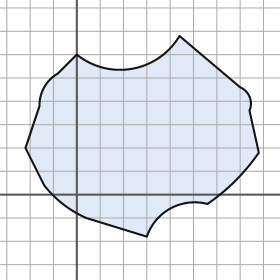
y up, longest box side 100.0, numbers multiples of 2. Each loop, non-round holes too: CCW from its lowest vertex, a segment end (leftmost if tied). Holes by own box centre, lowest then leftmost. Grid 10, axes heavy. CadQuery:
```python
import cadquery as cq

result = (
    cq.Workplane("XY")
    .moveTo(30.0, -18.0)
    .threePointArc((40.0, -6.0), (56.0, -4.0))
    .threePointArc((68.0, 6.0), (78.0, 18.0))
    .lineTo(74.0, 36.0)
    .threePointArc((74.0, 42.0), (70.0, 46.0))
    .lineTo(44.0, 68.0)
    .threePointArc((24.0, 54.0), (0.0, 60.0))
    .lineTo(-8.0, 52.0)
    .threePointArc((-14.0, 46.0), (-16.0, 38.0))
    .lineTo(-22.0, 20.0)
    .lineTo(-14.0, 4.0)
    .threePointArc((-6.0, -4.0), (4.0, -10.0))
    .close()
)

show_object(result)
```